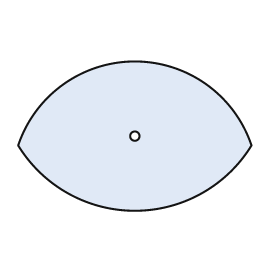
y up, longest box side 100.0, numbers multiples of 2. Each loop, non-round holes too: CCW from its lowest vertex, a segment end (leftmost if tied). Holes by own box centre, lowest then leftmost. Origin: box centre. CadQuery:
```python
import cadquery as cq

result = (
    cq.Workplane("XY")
    .moveTo(-50.0, -4.0)
    .threePointArc((0.0, -32.0), (50.0, -4.0))
    .threePointArc((0.0, 32.0), (-50.0, -4.0))
    .close()
    .moveTo(0.0, 0.0)
    .circle(2.0)
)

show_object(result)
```